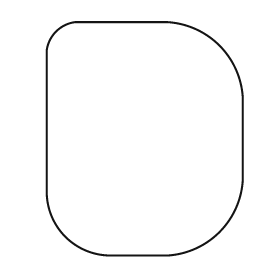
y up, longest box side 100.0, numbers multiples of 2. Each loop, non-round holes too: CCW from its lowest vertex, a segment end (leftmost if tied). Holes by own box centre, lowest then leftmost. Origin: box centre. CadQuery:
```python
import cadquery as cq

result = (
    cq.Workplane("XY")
    .moveTo(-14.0, -50.0)
    .lineTo(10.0, -50.0)
    .threePointArc((32.0, -40.0), (42.0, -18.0))
    .lineTo(42.0, 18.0)
    .threePointArc((32.0, 40.0), (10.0, 50.0))
    .lineTo(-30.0, 50.0)
    .threePointArc((-38.0, 46.0), (-42.0, 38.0))
    .lineTo(-42.0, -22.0)
    .threePointArc((-34.0, -42.0), (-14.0, -50.0))
    .close()
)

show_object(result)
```